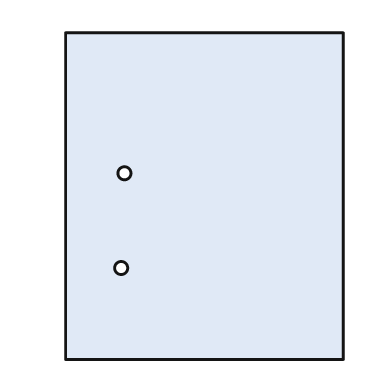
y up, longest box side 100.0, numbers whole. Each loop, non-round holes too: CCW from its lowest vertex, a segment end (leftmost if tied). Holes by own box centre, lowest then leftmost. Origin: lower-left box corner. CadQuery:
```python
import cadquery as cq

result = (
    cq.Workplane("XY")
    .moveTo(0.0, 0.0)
    .lineTo(85.0, 0.0)
    .lineTo(85.0, 100.0)
    .lineTo(0.0, 100.0)
    .close()
    .moveTo(17.0, 28.0)
    .circle(2.0)
    .moveTo(18.0, 57.0)
    .circle(2.0)
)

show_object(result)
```